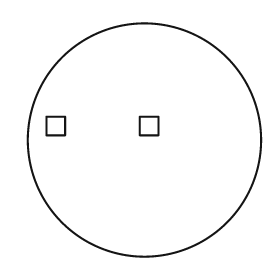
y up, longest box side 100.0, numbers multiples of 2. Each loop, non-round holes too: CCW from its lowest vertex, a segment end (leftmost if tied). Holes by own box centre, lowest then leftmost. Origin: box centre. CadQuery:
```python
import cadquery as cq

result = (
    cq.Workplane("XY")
    .moveTo(0.0, 0.0)
    .circle(50.0)
    .moveTo(-42.0, 2.0)
    .lineTo(-34.0, 2.0)
    .lineTo(-34.0, 10.0)
    .lineTo(-42.0, 10.0)
    .close()
    .moveTo(-2.0, 2.0)
    .lineTo(6.0, 2.0)
    .lineTo(6.0, 10.0)
    .lineTo(-2.0, 10.0)
    .close()
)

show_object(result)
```